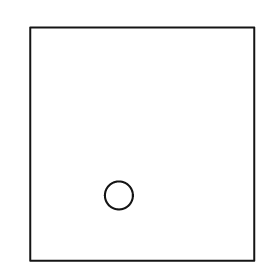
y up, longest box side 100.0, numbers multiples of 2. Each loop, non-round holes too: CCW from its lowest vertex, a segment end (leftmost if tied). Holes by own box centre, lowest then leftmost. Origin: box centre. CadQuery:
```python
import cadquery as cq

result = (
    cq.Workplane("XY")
    .moveTo(-48.0, -50.0)
    .lineTo(48.0, -50.0)
    .lineTo(48.0, 50.0)
    .lineTo(-48.0, 50.0)
    .close()
    .moveTo(-10.0, -22.0)
    .circle(6.0)
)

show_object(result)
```